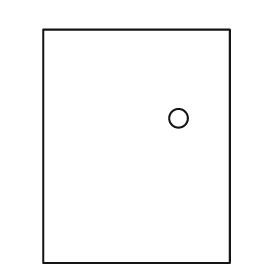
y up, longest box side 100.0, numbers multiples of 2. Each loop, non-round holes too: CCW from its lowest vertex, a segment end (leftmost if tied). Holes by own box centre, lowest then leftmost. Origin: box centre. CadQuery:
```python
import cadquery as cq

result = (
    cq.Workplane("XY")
    .moveTo(-40.0, -50.0)
    .lineTo(40.0, -50.0)
    .lineTo(40.0, 50.0)
    .lineTo(-40.0, 50.0)
    .close()
    .moveTo(18.0, 12.0)
    .circle(4.0)
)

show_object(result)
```